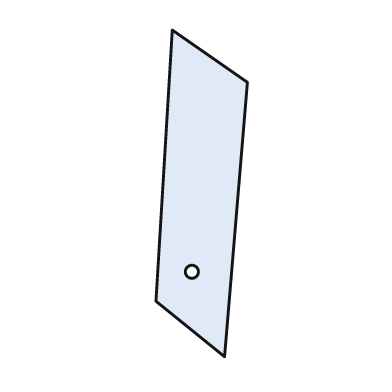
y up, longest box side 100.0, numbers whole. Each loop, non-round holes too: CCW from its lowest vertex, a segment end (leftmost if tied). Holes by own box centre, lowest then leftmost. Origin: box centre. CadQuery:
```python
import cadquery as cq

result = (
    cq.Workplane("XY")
    .moveTo(7.0, -50.0)
    .lineTo(14.0, 34.0)
    .lineTo(-9.0, 50.0)
    .lineTo(-14.0, -33.0)
    .close()
    .moveTo(-3.0, -24.0)
    .circle(2.0)
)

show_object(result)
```